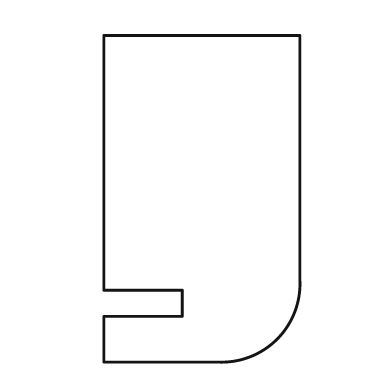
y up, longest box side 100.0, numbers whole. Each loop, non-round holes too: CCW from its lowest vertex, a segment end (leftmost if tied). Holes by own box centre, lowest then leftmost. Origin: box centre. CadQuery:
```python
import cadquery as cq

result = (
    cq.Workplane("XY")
    .moveTo(-30.0, -50.0)
    .lineTo(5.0, -50.0)
    .threePointArc((23.0, -43.0), (30.0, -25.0))
    .lineTo(30.0, 50.0)
    .lineTo(-30.0, 50.0)
    .lineTo(-30.0, -28.0)
    .lineTo(-6.0, -28.0)
    .lineTo(-6.0, -36.0)
    .lineTo(-30.0, -36.0)
    .close()
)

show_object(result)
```